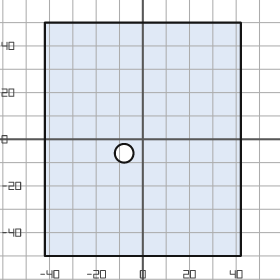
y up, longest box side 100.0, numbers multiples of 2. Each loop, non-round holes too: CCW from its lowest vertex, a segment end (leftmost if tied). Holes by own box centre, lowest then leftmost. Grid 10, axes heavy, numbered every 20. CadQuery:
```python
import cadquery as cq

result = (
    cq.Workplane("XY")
    .moveTo(-42.0, -50.0)
    .lineTo(42.0, -50.0)
    .lineTo(42.0, 50.0)
    .lineTo(-42.0, 50.0)
    .close()
    .moveTo(-8.0, -6.0)
    .circle(4.0)
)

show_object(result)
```